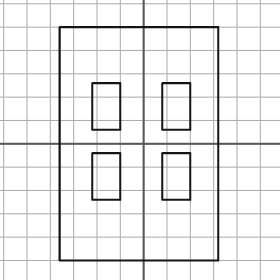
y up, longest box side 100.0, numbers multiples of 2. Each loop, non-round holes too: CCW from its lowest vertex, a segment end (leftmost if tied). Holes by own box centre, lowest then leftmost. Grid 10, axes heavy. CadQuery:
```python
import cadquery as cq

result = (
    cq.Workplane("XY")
    .moveTo(-36.0, -50.0)
    .lineTo(32.0, -50.0)
    .lineTo(32.0, 50.0)
    .lineTo(-36.0, 50.0)
    .close()
    .moveTo(-22.0, -24.0)
    .lineTo(-10.0, -24.0)
    .lineTo(-10.0, -4.0)
    .lineTo(-22.0, -4.0)
    .close()
    .moveTo(8.0, -24.0)
    .lineTo(20.0, -24.0)
    .lineTo(20.0, -4.0)
    .lineTo(8.0, -4.0)
    .close()
    .moveTo(-22.0, 6.0)
    .lineTo(-10.0, 6.0)
    .lineTo(-10.0, 26.0)
    .lineTo(-22.0, 26.0)
    .close()
    .moveTo(8.0, 6.0)
    .lineTo(20.0, 6.0)
    .lineTo(20.0, 26.0)
    .lineTo(8.0, 26.0)
    .close()
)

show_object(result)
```